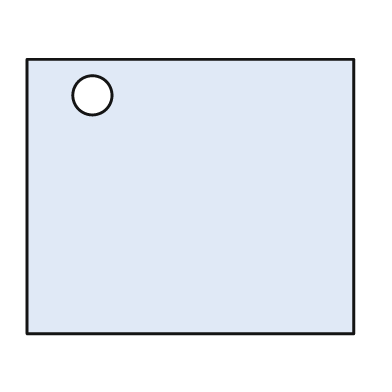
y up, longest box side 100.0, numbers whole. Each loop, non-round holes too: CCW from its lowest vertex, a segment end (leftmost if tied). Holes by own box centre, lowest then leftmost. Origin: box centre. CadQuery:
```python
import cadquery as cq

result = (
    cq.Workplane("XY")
    .moveTo(-50.0, -42.0)
    .lineTo(50.0, -42.0)
    .lineTo(50.0, 42.0)
    .lineTo(-50.0, 42.0)
    .close()
    .moveTo(-30.0, 31.0)
    .circle(6.0)
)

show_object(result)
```